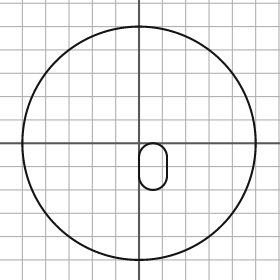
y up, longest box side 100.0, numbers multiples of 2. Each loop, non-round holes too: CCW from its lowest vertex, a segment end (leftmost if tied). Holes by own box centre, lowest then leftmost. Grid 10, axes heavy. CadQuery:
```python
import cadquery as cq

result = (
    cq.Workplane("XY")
    .moveTo(0.0, 0.0)
    .circle(50.0)
    .moveTo(0.0, -14.0)
    .threePointArc((6.0, -20.0), (12.0, -14.0))
    .lineTo(12.0, -6.0)
    .threePointArc((6.0, 0.0), (0.0, -6.0))
    .close()
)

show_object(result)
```